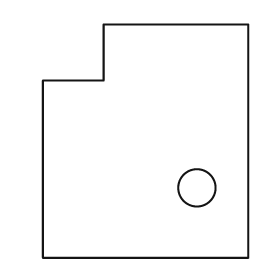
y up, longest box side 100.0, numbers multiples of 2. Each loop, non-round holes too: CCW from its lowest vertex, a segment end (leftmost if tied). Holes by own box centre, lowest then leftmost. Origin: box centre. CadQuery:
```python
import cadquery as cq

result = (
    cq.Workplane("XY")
    .moveTo(-44.0, -50.0)
    .lineTo(44.0, -50.0)
    .lineTo(44.0, 50.0)
    .lineTo(-18.0, 50.0)
    .lineTo(-18.0, 26.0)
    .lineTo(-44.0, 26.0)
    .close()
    .moveTo(22.0, -20.0)
    .circle(8.0)
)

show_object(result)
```